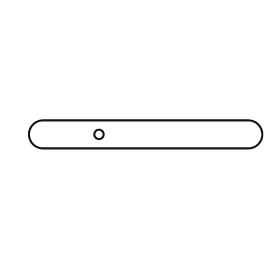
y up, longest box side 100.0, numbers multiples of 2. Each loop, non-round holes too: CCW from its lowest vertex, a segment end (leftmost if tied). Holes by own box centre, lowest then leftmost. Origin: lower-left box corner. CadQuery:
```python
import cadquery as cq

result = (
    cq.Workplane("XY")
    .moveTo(6.0, 0.0)
    .lineTo(94.0, 0.0)
    .threePointArc((100.0, 6.0), (94.0, 12.0))
    .lineTo(6.0, 12.0)
    .threePointArc((0.0, 6.0), (6.0, 0.0))
    .close()
    .moveTo(30.0, 6.0)
    .circle(2.0)
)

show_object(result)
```